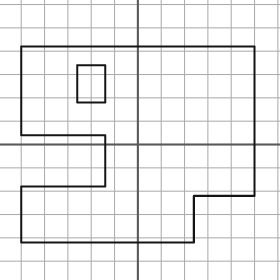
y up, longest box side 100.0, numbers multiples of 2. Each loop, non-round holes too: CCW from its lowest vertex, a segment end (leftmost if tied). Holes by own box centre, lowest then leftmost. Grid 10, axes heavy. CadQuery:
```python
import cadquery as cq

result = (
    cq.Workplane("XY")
    .moveTo(-50.0, -42.0)
    .lineTo(24.0, -42.0)
    .lineTo(24.0, -22.0)
    .lineTo(50.0, -22.0)
    .lineTo(50.0, 42.0)
    .lineTo(-50.0, 42.0)
    .lineTo(-50.0, 4.0)
    .lineTo(-14.0, 4.0)
    .lineTo(-14.0, -18.0)
    .lineTo(-50.0, -18.0)
    .close()
    .moveTo(-26.0, 18.0)
    .lineTo(-14.0, 18.0)
    .lineTo(-14.0, 34.0)
    .lineTo(-26.0, 34.0)
    .close()
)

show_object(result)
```